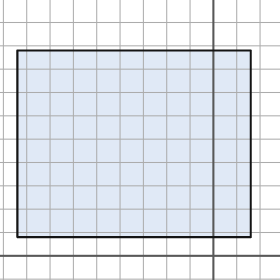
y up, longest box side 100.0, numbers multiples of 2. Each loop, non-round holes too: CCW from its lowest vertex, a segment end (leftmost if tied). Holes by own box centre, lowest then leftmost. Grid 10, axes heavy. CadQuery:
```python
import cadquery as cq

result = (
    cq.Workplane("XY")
    .moveTo(-84.0, 8.0)
    .lineTo(16.0, 8.0)
    .lineTo(16.0, 88.0)
    .lineTo(-84.0, 88.0)
    .close()
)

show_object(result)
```